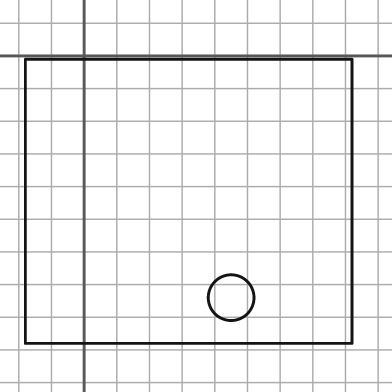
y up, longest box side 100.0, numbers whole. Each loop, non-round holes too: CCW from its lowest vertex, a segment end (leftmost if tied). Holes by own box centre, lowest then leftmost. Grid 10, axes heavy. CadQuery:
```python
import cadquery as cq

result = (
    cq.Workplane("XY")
    .moveTo(-18.0, -88.0)
    .lineTo(82.0, -88.0)
    .lineTo(82.0, -1.0)
    .lineTo(-18.0, -1.0)
    .close()
    .moveTo(45.0, -74.0)
    .circle(7.0)
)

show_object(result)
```